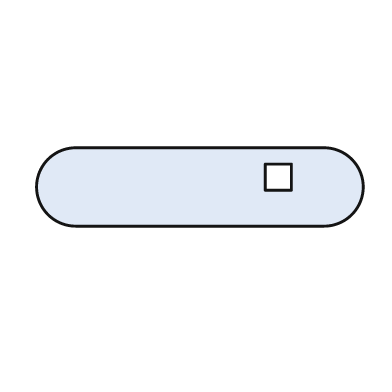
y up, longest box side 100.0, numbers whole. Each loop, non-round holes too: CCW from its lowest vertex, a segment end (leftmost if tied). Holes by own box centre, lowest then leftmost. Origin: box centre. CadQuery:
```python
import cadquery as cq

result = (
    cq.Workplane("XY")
    .moveTo(-38.0, -12.0)
    .lineTo(38.0, -12.0)
    .threePointArc((50.0, 0.0), (38.0, 12.0))
    .lineTo(-38.0, 12.0)
    .threePointArc((-50.0, 0.0), (-38.0, -12.0))
    .close()
    .moveTo(20.0, -1.0)
    .lineTo(28.0, -1.0)
    .lineTo(28.0, 7.0)
    .lineTo(20.0, 7.0)
    .close()
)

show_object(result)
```